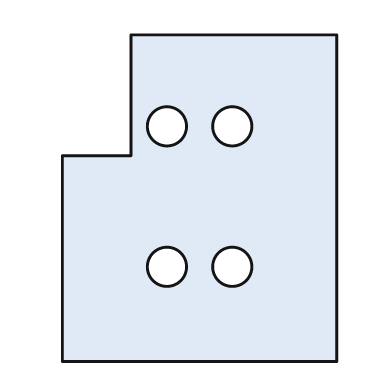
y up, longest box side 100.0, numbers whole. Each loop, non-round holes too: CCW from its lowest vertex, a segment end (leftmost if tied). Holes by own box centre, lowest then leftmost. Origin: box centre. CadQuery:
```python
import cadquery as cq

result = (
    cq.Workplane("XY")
    .moveTo(-42.0, -50.0)
    .lineTo(42.0, -50.0)
    .lineTo(42.0, 50.0)
    .lineTo(-21.0, 50.0)
    .lineTo(-21.0, 13.0)
    .lineTo(-42.0, 13.0)
    .close()
    .moveTo(-10.0, -21.0)
    .circle(6.0)
    .moveTo(10.0, -21.0)
    .circle(6.0)
    .moveTo(-10.0, 22.0)
    .circle(6.0)
    .moveTo(10.0, 22.0)
    .circle(6.0)
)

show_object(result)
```